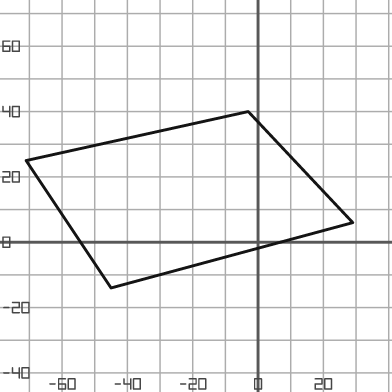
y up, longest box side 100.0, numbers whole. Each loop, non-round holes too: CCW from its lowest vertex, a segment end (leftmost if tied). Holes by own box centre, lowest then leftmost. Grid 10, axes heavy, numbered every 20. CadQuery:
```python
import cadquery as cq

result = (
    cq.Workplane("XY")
    .moveTo(-45.0, -14.0)
    .lineTo(29.0, 6.0)
    .lineTo(-3.0, 40.0)
    .lineTo(-71.0, 25.0)
    .close()
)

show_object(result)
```